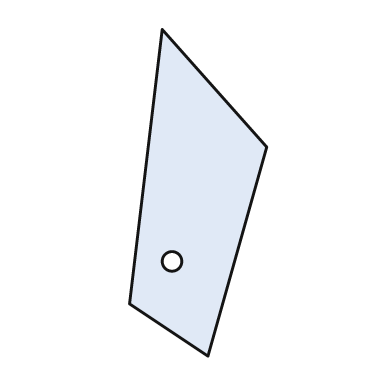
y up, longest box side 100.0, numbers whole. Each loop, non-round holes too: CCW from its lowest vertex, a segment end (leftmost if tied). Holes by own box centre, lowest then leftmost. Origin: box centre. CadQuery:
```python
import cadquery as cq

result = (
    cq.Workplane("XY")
    .moveTo(3.0, -50.0)
    .lineTo(21.0, 14.0)
    .lineTo(-11.0, 50.0)
    .lineTo(-21.0, -34.0)
    .close()
    .moveTo(-8.0, -21.0)
    .circle(3.0)
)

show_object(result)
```